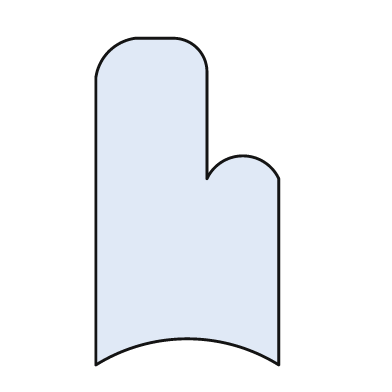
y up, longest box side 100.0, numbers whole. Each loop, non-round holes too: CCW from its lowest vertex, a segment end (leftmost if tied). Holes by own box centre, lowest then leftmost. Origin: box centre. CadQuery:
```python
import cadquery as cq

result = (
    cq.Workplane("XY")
    .moveTo(-28.0, -50.0)
    .threePointArc((0.0, -42.0), (28.0, -50.0))
    .lineTo(28.0, 7.0)
    .threePointArc((17.0, 14.0), (6.0, 7.0))
    .lineTo(6.0, 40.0)
    .threePointArc((3.0, 47.0), (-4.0, 50.0))
    .lineTo(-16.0, 50.0)
    .threePointArc((-24.0, 46.0), (-28.0, 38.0))
    .close()
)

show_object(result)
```